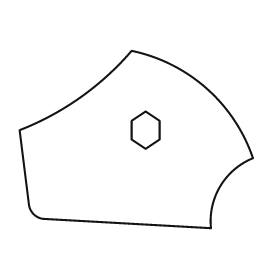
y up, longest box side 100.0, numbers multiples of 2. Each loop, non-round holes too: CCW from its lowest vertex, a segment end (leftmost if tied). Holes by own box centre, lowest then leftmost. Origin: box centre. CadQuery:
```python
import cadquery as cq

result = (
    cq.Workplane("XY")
    .moveTo(32.0, -38.0)
    .threePointArc((36.0, -20.0), (50.0, -8.0))
    .threePointArc((30.0, 22.0), (-2.0, 38.0))
    .threePointArc((-24.0, 18.0), (-50.0, 4.0))
    .lineTo(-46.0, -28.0)
    .threePointArc((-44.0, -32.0), (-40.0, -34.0))
    .close()
    .moveTo(4.0, -4.0)
    .lineTo(10.0, 0.0)
    .lineTo(10.0, 8.0)
    .lineTo(4.0, 12.0)
    .lineTo(-2.0, 8.0)
    .lineTo(-2.0, 0.0)
    .close()
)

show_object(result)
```